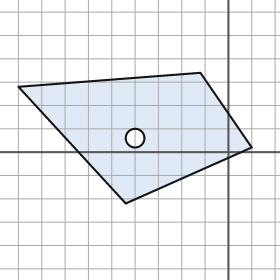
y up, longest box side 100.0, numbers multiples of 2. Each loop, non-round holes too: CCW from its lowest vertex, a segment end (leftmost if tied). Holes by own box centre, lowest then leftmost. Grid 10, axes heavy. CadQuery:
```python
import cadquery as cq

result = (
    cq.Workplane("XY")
    .moveTo(-44.0, -22.0)
    .lineTo(10.0, 2.0)
    .lineTo(-12.0, 34.0)
    .lineTo(-90.0, 28.0)
    .close()
    .moveTo(-40.0, 6.0)
    .circle(4.0)
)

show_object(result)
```